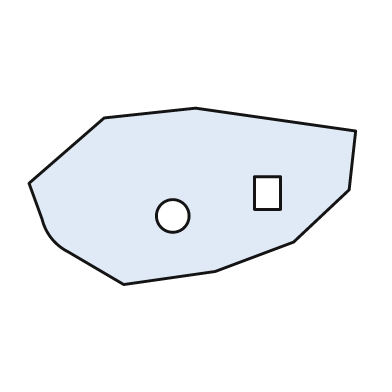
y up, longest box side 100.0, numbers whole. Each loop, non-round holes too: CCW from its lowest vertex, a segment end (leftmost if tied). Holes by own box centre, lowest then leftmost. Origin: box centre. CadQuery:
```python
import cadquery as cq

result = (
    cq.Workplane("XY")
    .moveTo(-21.0, -27.0)
    .lineTo(7.0, -23.0)
    .lineTo(31.0, -14.0)
    .lineTo(48.0, 2.0)
    .lineTo(50.0, 20.0)
    .lineTo(1.0, 27.0)
    .lineTo(-27.0, 24.0)
    .lineTo(-50.0, 4.0)
    .lineTo(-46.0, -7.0)
    .threePointArc((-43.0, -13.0), (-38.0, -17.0))
    .close()
    .moveTo(-6.0, -6.0)
    .circle(5.0)
    .moveTo(19.0, -4.0)
    .lineTo(27.0, -4.0)
    .lineTo(27.0, 6.0)
    .lineTo(19.0, 6.0)
    .close()
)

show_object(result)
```